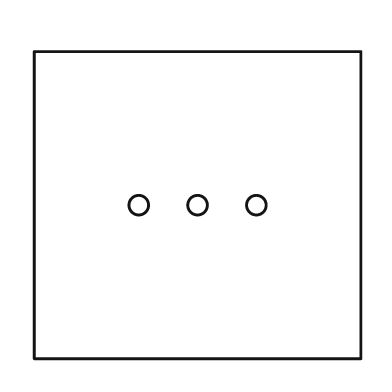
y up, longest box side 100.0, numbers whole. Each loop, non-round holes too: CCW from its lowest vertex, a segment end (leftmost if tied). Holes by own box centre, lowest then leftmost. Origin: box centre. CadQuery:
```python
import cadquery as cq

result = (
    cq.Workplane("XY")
    .moveTo(-50.0, -47.0)
    .lineTo(50.0, -47.0)
    .lineTo(50.0, 47.0)
    .lineTo(-50.0, 47.0)
    .close()
    .moveTo(-18.0, 0.0)
    .circle(3.0)
    .moveTo(0.0, 0.0)
    .circle(3.0)
    .moveTo(18.0, 0.0)
    .circle(3.0)
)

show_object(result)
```